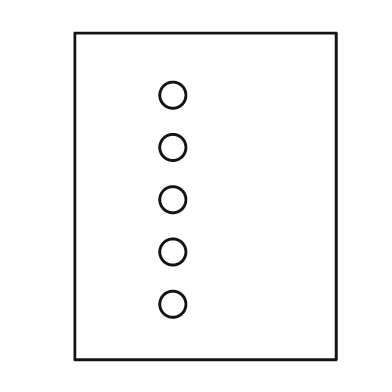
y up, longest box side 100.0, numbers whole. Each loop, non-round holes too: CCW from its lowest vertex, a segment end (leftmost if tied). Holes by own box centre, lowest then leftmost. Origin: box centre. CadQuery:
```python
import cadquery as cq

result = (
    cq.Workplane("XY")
    .moveTo(-40.0, -50.0)
    .lineTo(40.0, -50.0)
    .lineTo(40.0, 50.0)
    .lineTo(-40.0, 50.0)
    .close()
    .moveTo(-10.0, -33.0)
    .circle(4.0)
    .moveTo(-10.0, -17.0)
    .circle(4.0)
    .moveTo(-10.0, -1.0)
    .circle(4.0)
    .moveTo(-10.0, 15.0)
    .circle(4.0)
    .moveTo(-10.0, 31.0)
    .circle(4.0)
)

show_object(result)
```